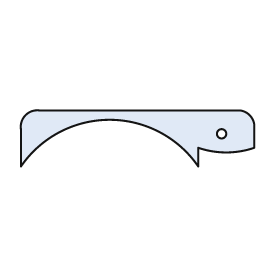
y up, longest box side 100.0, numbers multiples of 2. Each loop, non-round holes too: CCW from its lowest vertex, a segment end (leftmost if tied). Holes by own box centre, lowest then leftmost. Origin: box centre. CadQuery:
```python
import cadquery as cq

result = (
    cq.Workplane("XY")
    .moveTo(-50.0, -12.0)
    .threePointArc((-12.0, 8.0), (26.0, -12.0))
    .lineTo(26.0, -4.0)
    .threePointArc((38.0, -6.0), (50.0, -4.0))
    .lineTo(50.0, 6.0)
    .threePointArc((48.0, 10.0), (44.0, 12.0))
    .lineTo(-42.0, 12.0)
    .threePointArc((-48.0, 10.0), (-50.0, 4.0))
    .close()
    .moveTo(36.0, 2.0)
    .circle(2.0)
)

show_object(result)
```